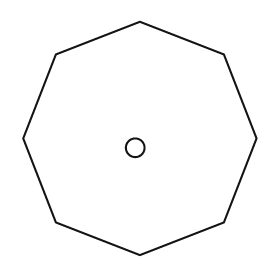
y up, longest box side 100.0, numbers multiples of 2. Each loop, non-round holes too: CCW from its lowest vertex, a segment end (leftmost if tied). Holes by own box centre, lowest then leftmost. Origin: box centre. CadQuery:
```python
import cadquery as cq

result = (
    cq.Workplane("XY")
    .moveTo(0.0, -50.0)
    .lineTo(36.0, -36.0)
    .lineTo(50.0, 0.0)
    .lineTo(36.0, 36.0)
    .lineTo(0.0, 50.0)
    .lineTo(-36.0, 36.0)
    .lineTo(-50.0, 0.0)
    .lineTo(-36.0, -36.0)
    .close()
    .moveTo(-2.0, -4.0)
    .circle(4.0)
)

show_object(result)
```